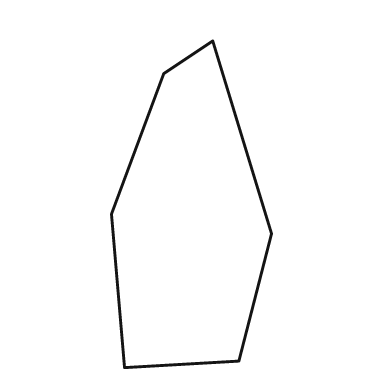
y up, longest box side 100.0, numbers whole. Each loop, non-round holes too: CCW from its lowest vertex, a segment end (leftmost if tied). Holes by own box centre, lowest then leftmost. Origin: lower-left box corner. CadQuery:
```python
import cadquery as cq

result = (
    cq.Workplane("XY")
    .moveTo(4.0, 0.0)
    .lineTo(39.0, 2.0)
    .lineTo(49.0, 41.0)
    .lineTo(31.0, 100.0)
    .lineTo(16.0, 90.0)
    .lineTo(0.0, 47.0)
    .close()
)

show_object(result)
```